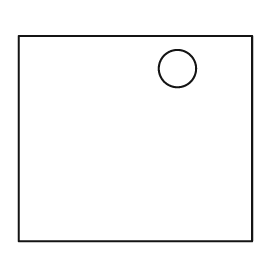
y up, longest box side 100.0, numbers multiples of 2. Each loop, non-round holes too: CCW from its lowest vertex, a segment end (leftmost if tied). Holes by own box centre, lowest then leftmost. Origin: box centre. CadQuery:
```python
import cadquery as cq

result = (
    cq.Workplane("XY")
    .moveTo(-50.0, -44.0)
    .lineTo(50.0, -44.0)
    .lineTo(50.0, 44.0)
    .lineTo(-50.0, 44.0)
    .close()
    .moveTo(18.0, 30.0)
    .circle(8.0)
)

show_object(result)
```